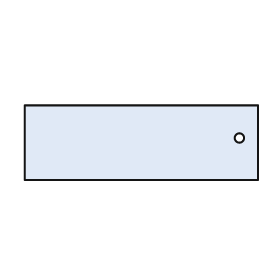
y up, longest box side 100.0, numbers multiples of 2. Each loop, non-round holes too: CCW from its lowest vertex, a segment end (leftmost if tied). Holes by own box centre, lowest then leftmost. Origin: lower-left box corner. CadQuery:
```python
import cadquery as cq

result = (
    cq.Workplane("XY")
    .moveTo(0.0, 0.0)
    .lineTo(100.0, 0.0)
    .lineTo(100.0, 32.0)
    .lineTo(0.0, 32.0)
    .close()
    .moveTo(92.0, 18.0)
    .circle(2.0)
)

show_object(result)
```